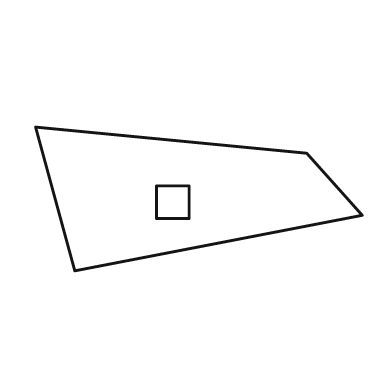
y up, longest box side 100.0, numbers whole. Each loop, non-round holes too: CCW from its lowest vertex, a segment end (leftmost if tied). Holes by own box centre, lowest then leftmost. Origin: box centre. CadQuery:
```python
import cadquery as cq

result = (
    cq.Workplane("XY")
    .moveTo(-38.0, -22.0)
    .lineTo(50.0, -5.0)
    .lineTo(33.0, 14.0)
    .lineTo(-50.0, 22.0)
    .close()
    .moveTo(-13.0, -6.0)
    .lineTo(-3.0, -6.0)
    .lineTo(-3.0, 4.0)
    .lineTo(-13.0, 4.0)
    .close()
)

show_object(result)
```